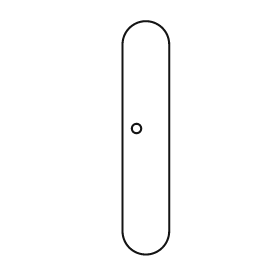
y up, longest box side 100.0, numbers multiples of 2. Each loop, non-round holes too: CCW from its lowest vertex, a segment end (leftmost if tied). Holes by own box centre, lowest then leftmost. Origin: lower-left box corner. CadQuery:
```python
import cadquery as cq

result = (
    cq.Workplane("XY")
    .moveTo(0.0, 10.0)
    .threePointArc((10.0, 0.0), (20.0, 10.0))
    .lineTo(20.0, 90.0)
    .threePointArc((10.0, 100.0), (0.0, 90.0))
    .close()
    .moveTo(6.0, 54.0)
    .circle(2.0)
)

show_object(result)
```